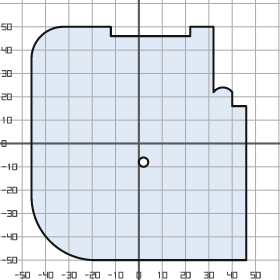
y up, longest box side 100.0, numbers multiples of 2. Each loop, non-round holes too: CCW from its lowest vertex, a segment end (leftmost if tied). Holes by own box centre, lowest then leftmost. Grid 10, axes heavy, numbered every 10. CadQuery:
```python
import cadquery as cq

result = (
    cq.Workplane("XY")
    .moveTo(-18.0, -50.0)
    .lineTo(46.0, -50.0)
    .lineTo(46.0, 16.0)
    .lineTo(40.0, 16.0)
    .lineTo(40.0, 22.0)
    .threePointArc((36.0, 24.0), (32.0, 22.0))
    .lineTo(32.0, 50.0)
    .lineTo(22.0, 50.0)
    .lineTo(22.0, 46.0)
    .lineTo(-12.0, 46.0)
    .lineTo(-12.0, 50.0)
    .lineTo(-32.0, 50.0)
    .threePointArc((-42.0, 46.0), (-46.0, 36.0))
    .lineTo(-46.0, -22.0)
    .threePointArc((-38.0, -42.0), (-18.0, -50.0))
    .close()
    .moveTo(2.0, -8.0)
    .circle(2.0)
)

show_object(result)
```